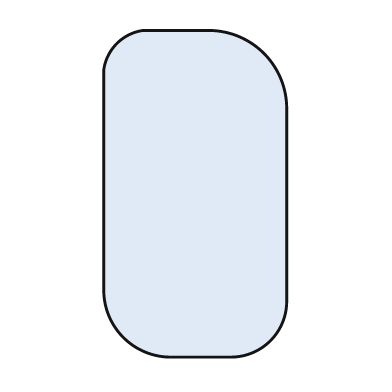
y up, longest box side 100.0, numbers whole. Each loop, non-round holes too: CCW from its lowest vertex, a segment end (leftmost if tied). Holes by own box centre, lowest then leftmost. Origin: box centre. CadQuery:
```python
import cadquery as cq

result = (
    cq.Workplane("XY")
    .moveTo(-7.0, -50.0)
    .lineTo(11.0, -50.0)
    .threePointArc((23.0, -45.0), (28.0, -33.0))
    .lineTo(28.0, 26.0)
    .threePointArc((21.0, 43.0), (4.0, 50.0))
    .lineTo(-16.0, 50.0)
    .threePointArc((-24.0, 46.0), (-28.0, 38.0))
    .lineTo(-28.0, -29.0)
    .threePointArc((-22.0, -44.0), (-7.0, -50.0))
    .close()
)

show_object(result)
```